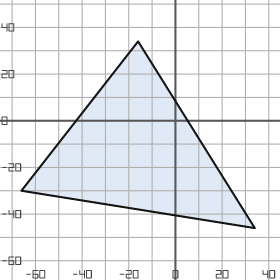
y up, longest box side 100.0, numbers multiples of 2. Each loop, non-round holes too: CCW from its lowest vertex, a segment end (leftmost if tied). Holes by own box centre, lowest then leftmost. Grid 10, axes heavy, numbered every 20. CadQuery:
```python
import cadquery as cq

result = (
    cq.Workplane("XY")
    .moveTo(34.0, -46.0)
    .lineTo(-16.0, 34.0)
    .lineTo(-66.0, -30.0)
    .close()
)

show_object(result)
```